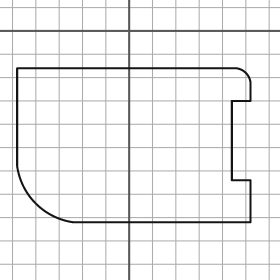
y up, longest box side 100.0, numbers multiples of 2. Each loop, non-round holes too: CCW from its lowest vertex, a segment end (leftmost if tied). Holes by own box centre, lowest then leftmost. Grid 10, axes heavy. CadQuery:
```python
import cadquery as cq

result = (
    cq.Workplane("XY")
    .moveTo(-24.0, -82.0)
    .lineTo(52.0, -82.0)
    .lineTo(52.0, -64.0)
    .lineTo(44.0, -64.0)
    .lineTo(44.0, -30.0)
    .lineTo(52.0, -30.0)
    .lineTo(52.0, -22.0)
    .threePointArc((50.0, -18.0), (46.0, -16.0))
    .lineTo(-48.0, -16.0)
    .lineTo(-48.0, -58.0)
    .threePointArc((-40.0, -74.0), (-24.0, -82.0))
    .close()
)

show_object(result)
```